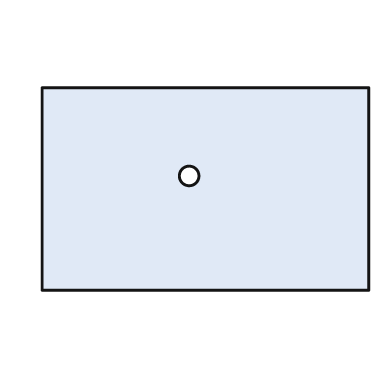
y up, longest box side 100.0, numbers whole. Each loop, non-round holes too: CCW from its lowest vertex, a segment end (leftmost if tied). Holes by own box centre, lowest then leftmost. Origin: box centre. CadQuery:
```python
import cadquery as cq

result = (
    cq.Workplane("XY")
    .moveTo(-50.0, -31.0)
    .lineTo(50.0, -31.0)
    .lineTo(50.0, 31.0)
    .lineTo(-50.0, 31.0)
    .close()
    .moveTo(-5.0, 4.0)
    .circle(3.0)
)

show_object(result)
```